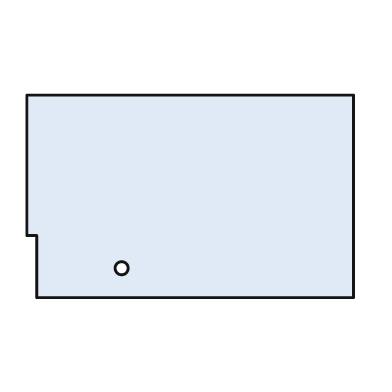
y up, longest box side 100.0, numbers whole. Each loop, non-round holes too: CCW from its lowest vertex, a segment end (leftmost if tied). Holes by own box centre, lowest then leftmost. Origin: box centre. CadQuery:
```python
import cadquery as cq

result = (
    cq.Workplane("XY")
    .moveTo(-47.0, -31.0)
    .lineTo(50.0, -31.0)
    .lineTo(50.0, 31.0)
    .lineTo(-50.0, 31.0)
    .lineTo(-50.0, -12.0)
    .lineTo(-47.0, -12.0)
    .close()
    .moveTo(-21.0, -22.0)
    .circle(2.0)
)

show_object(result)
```